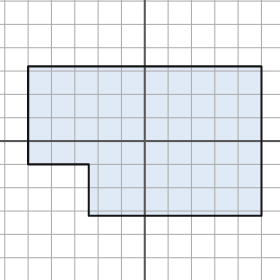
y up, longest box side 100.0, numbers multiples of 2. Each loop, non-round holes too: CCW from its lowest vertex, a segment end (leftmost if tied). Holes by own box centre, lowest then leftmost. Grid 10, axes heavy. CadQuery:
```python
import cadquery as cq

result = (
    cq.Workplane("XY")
    .moveTo(-24.0, -32.0)
    .lineTo(50.0, -32.0)
    .lineTo(50.0, 32.0)
    .lineTo(-50.0, 32.0)
    .lineTo(-50.0, -10.0)
    .lineTo(-24.0, -10.0)
    .close()
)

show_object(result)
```